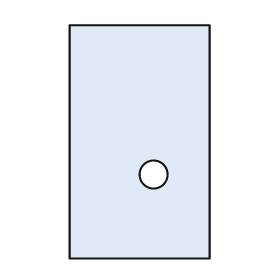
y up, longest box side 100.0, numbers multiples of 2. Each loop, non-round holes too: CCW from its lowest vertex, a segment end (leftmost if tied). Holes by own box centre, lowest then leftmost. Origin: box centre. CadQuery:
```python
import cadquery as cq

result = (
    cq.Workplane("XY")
    .moveTo(-30.0, -50.0)
    .lineTo(30.0, -50.0)
    .lineTo(30.0, 50.0)
    .lineTo(-30.0, 50.0)
    .close()
    .moveTo(6.0, -14.0)
    .circle(6.0)
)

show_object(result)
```